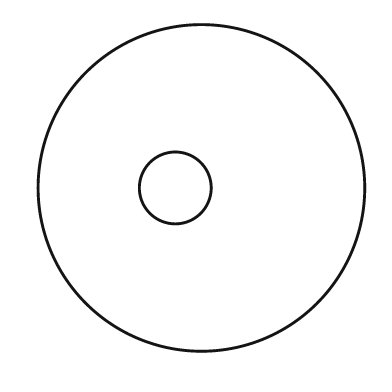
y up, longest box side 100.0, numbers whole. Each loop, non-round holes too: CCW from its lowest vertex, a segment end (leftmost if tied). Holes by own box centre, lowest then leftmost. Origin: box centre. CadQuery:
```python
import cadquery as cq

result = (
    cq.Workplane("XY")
    .moveTo(0.0, 0.0)
    .circle(50.0)
    .moveTo(-8.0, 0.0)
    .circle(11.0)
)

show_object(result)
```